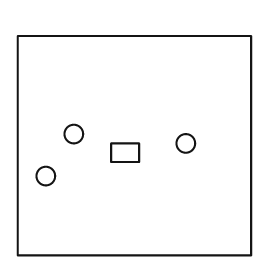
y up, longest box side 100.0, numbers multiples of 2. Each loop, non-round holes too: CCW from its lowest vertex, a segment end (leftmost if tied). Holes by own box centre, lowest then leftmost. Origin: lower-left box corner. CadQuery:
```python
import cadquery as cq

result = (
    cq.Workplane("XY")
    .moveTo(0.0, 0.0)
    .lineTo(100.0, 0.0)
    .lineTo(100.0, 94.0)
    .lineTo(0.0, 94.0)
    .close()
    .moveTo(12.0, 34.0)
    .circle(4.0)
    .moveTo(40.0, 40.0)
    .lineTo(52.0, 40.0)
    .lineTo(52.0, 48.0)
    .lineTo(40.0, 48.0)
    .close()
    .moveTo(72.0, 48.0)
    .circle(4.0)
    .moveTo(24.0, 52.0)
    .circle(4.0)
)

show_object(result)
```